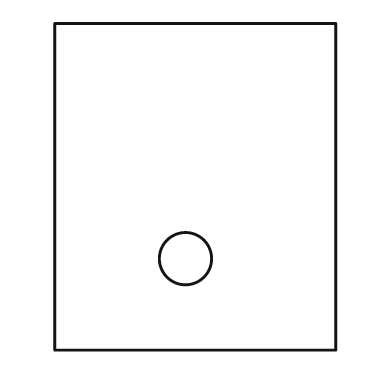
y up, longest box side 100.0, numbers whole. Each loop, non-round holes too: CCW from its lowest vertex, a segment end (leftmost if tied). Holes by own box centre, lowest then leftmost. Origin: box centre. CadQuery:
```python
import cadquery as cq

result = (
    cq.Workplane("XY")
    .moveTo(-43.0, -50.0)
    .lineTo(43.0, -50.0)
    .lineTo(43.0, 50.0)
    .lineTo(-43.0, 50.0)
    .close()
    .moveTo(-3.0, -22.0)
    .circle(8.0)
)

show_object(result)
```